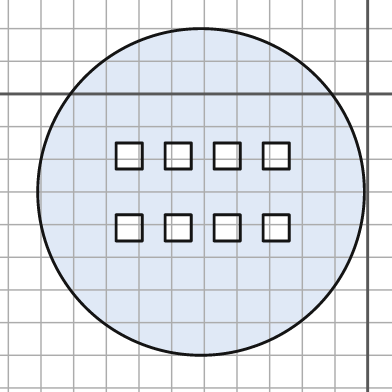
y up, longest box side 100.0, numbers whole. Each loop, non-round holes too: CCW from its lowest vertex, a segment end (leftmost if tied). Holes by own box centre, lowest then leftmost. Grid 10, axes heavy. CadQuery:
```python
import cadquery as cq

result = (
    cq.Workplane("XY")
    .moveTo(-51.0, -30.0)
    .circle(50.0)
    .moveTo(-77.0, -45.0)
    .lineTo(-69.0, -45.0)
    .lineTo(-69.0, -37.0)
    .lineTo(-77.0, -37.0)
    .close()
    .moveTo(-62.0, -45.0)
    .lineTo(-54.0, -45.0)
    .lineTo(-54.0, -37.0)
    .lineTo(-62.0, -37.0)
    .close()
    .moveTo(-47.0, -45.0)
    .lineTo(-39.0, -45.0)
    .lineTo(-39.0, -37.0)
    .lineTo(-47.0, -37.0)
    .close()
    .moveTo(-32.0, -45.0)
    .lineTo(-24.0, -45.0)
    .lineTo(-24.0, -37.0)
    .lineTo(-32.0, -37.0)
    .close()
    .moveTo(-77.0, -23.0)
    .lineTo(-69.0, -23.0)
    .lineTo(-69.0, -15.0)
    .lineTo(-77.0, -15.0)
    .close()
    .moveTo(-62.0, -23.0)
    .lineTo(-54.0, -23.0)
    .lineTo(-54.0, -15.0)
    .lineTo(-62.0, -15.0)
    .close()
    .moveTo(-47.0, -23.0)
    .lineTo(-39.0, -23.0)
    .lineTo(-39.0, -15.0)
    .lineTo(-47.0, -15.0)
    .close()
    .moveTo(-32.0, -23.0)
    .lineTo(-24.0, -23.0)
    .lineTo(-24.0, -15.0)
    .lineTo(-32.0, -15.0)
    .close()
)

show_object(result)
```